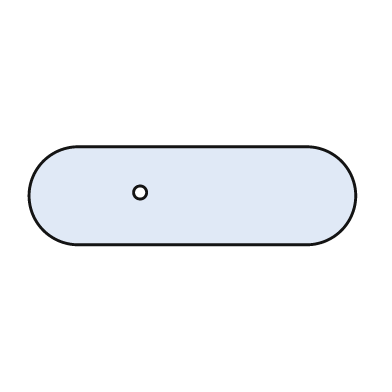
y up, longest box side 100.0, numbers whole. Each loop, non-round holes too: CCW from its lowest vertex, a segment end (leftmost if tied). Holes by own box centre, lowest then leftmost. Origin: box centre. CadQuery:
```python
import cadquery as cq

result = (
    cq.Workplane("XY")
    .moveTo(-35.0, -15.0)
    .lineTo(35.0, -15.0)
    .threePointArc((50.0, 0.0), (35.0, 15.0))
    .lineTo(-35.0, 15.0)
    .threePointArc((-50.0, 0.0), (-35.0, -15.0))
    .close()
    .moveTo(-16.0, 1.0)
    .circle(2.0)
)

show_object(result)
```